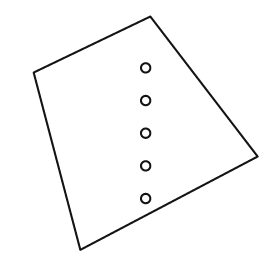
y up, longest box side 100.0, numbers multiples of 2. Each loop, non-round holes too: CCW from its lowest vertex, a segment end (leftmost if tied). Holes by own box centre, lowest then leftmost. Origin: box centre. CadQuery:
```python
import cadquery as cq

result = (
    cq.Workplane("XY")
    .moveTo(-28.0, -50.0)
    .lineTo(48.0, -10.0)
    .lineTo(2.0, 50.0)
    .lineTo(-48.0, 26.0)
    .close()
    .moveTo(0.0, -28.0)
    .circle(2.0)
    .moveTo(0.0, -14.0)
    .circle(2.0)
    .moveTo(0.0, 0.0)
    .circle(2.0)
    .moveTo(0.0, 14.0)
    .circle(2.0)
    .moveTo(0.0, 28.0)
    .circle(2.0)
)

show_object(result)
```